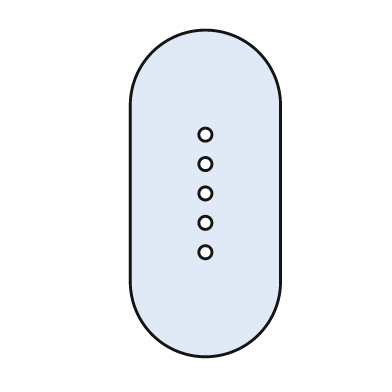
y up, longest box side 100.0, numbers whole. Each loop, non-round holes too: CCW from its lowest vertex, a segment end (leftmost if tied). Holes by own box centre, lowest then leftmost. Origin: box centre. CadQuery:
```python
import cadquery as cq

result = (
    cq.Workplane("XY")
    .moveTo(-23.0, -27.0)
    .threePointArc((0.0, -50.0), (23.0, -27.0))
    .lineTo(23.0, 27.0)
    .threePointArc((0.0, 50.0), (-23.0, 27.0))
    .close()
    .moveTo(0.0, -18.0)
    .circle(2.0)
    .moveTo(0.0, -9.0)
    .circle(2.0)
    .moveTo(0.0, 0.0)
    .circle(2.0)
    .moveTo(0.0, 9.0)
    .circle(2.0)
    .moveTo(0.0, 18.0)
    .circle(2.0)
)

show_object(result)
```